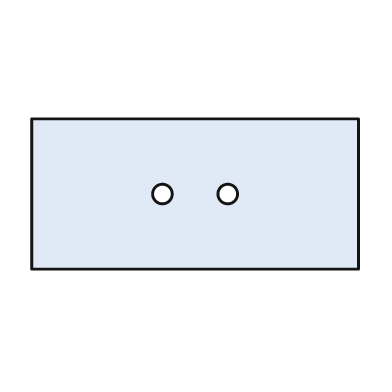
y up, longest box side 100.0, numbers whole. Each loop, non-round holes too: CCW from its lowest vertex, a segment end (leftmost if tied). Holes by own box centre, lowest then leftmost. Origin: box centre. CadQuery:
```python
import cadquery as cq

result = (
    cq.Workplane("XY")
    .moveTo(-50.0, -23.0)
    .lineTo(50.0, -23.0)
    .lineTo(50.0, 23.0)
    .lineTo(-50.0, 23.0)
    .close()
    .moveTo(-10.0, 0.0)
    .circle(3.0)
    .moveTo(10.0, 0.0)
    .circle(3.0)
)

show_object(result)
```